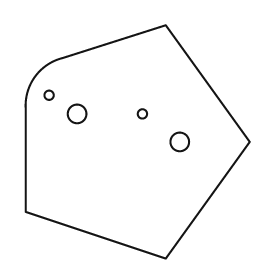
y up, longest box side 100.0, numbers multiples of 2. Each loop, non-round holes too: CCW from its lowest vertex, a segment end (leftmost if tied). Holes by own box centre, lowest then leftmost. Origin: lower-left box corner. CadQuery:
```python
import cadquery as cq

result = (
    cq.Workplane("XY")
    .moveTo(60.0, 0.0)
    .lineTo(96.0, 50.0)
    .lineTo(60.0, 100.0)
    .lineTo(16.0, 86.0)
    .threePointArc((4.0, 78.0), (0.0, 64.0))
    .lineTo(0.0, 20.0)
    .close()
    .moveTo(66.0, 50.0)
    .circle(4.0)
    .moveTo(22.0, 62.0)
    .circle(4.0)
    .moveTo(50.0, 62.0)
    .circle(2.0)
    .moveTo(10.0, 70.0)
    .circle(2.0)
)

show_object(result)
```